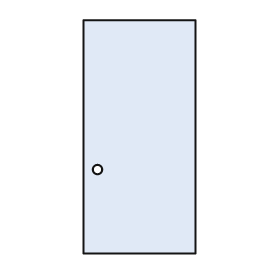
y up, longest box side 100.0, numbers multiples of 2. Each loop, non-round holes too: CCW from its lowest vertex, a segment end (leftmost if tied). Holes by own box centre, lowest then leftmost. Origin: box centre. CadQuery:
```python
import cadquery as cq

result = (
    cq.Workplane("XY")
    .moveTo(-24.0, -50.0)
    .lineTo(24.0, -50.0)
    .lineTo(24.0, 50.0)
    .lineTo(-24.0, 50.0)
    .close()
    .moveTo(-18.0, -14.0)
    .circle(2.0)
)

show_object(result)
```